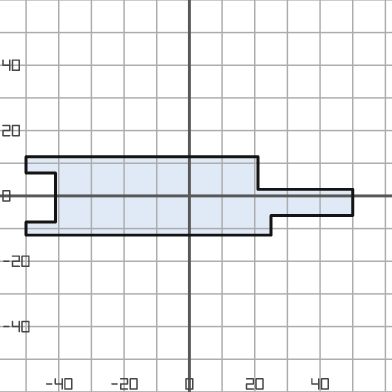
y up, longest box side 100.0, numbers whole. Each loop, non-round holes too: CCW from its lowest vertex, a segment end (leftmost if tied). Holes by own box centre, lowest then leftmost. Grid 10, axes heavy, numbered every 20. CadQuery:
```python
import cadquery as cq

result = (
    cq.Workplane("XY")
    .moveTo(-50.0, -12.0)
    .lineTo(25.0, -12.0)
    .lineTo(25.0, -6.0)
    .lineTo(50.0, -6.0)
    .lineTo(50.0, 2.0)
    .lineTo(21.0, 2.0)
    .lineTo(21.0, 12.0)
    .lineTo(-50.0, 12.0)
    .lineTo(-50.0, 7.0)
    .lineTo(-41.0, 7.0)
    .lineTo(-41.0, -8.0)
    .lineTo(-50.0, -8.0)
    .close()
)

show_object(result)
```